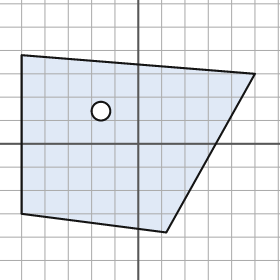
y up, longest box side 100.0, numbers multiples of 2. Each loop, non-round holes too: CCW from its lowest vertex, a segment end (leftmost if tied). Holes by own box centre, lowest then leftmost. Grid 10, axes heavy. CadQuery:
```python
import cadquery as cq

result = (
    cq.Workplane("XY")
    .moveTo(12.0, -38.0)
    .lineTo(50.0, 30.0)
    .lineTo(-50.0, 38.0)
    .lineTo(-50.0, -30.0)
    .close()
    .moveTo(-16.0, 14.0)
    .circle(4.0)
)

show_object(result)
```